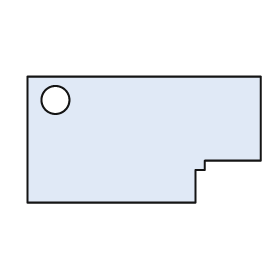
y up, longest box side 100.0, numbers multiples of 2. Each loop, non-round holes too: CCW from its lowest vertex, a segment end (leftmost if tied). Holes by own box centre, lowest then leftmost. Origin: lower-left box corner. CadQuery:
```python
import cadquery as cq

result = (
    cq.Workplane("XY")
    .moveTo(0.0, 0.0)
    .lineTo(72.0, 0.0)
    .lineTo(72.0, 14.0)
    .lineTo(76.0, 14.0)
    .lineTo(76.0, 18.0)
    .lineTo(100.0, 18.0)
    .lineTo(100.0, 54.0)
    .lineTo(0.0, 54.0)
    .close()
    .moveTo(12.0, 44.0)
    .circle(6.0)
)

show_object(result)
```